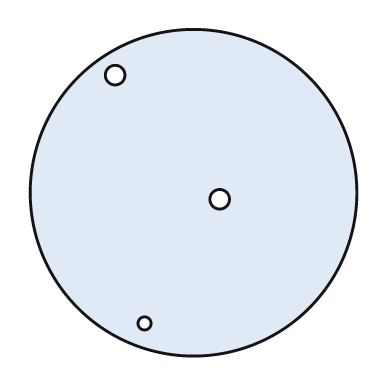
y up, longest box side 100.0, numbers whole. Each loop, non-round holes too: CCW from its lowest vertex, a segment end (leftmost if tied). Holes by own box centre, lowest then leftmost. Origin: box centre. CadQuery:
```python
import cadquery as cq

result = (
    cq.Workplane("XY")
    .moveTo(0.0, 0.0)
    .circle(50.0)
    .moveTo(-15.0, -40.0)
    .circle(2.0)
    .moveTo(8.0, -2.0)
    .circle(3.0)
    .moveTo(-24.0, 36.0)
    .circle(3.0)
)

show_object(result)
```